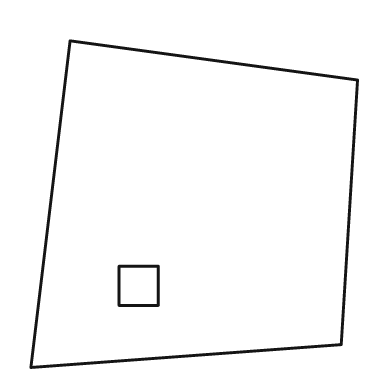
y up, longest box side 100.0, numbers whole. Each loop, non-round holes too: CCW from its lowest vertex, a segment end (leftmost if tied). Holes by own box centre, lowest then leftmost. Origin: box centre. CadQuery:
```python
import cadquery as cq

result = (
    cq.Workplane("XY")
    .moveTo(-50.0, -50.0)
    .lineTo(45.0, -43.0)
    .lineTo(50.0, 38.0)
    .lineTo(-38.0, 50.0)
    .close()
    .moveTo(-23.0, -31.0)
    .lineTo(-11.0, -31.0)
    .lineTo(-11.0, -19.0)
    .lineTo(-23.0, -19.0)
    .close()
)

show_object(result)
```